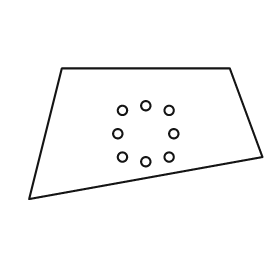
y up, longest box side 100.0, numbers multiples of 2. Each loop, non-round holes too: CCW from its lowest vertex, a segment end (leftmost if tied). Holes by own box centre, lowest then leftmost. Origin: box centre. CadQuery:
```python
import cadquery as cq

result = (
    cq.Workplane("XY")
    .moveTo(-50.0, -28.0)
    .lineTo(50.0, -10.0)
    .lineTo(36.0, 28.0)
    .lineTo(-36.0, 28.0)
    .close()
    .moveTo(0.0, -12.0)
    .circle(2.0)
    .moveTo(-10.0, -10.0)
    .circle(2.0)
    .moveTo(10.0, -10.0)
    .circle(2.0)
    .moveTo(-12.0, 0.0)
    .circle(2.0)
    .moveTo(12.0, 0.0)
    .circle(2.0)
    .moveTo(-10.0, 10.0)
    .circle(2.0)
    .moveTo(10.0, 10.0)
    .circle(2.0)
    .moveTo(0.0, 12.0)
    .circle(2.0)
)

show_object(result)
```